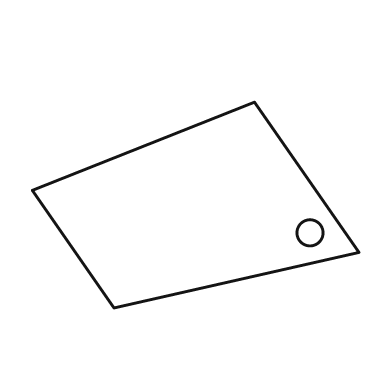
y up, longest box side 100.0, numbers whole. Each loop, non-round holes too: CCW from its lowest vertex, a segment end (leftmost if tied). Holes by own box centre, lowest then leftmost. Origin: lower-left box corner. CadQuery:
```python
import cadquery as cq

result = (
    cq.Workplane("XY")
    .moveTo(25.0, 0.0)
    .lineTo(100.0, 17.0)
    .lineTo(68.0, 63.0)
    .lineTo(0.0, 36.0)
    .close()
    .moveTo(85.0, 23.0)
    .circle(4.0)
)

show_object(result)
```